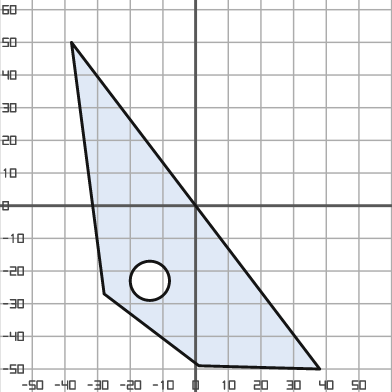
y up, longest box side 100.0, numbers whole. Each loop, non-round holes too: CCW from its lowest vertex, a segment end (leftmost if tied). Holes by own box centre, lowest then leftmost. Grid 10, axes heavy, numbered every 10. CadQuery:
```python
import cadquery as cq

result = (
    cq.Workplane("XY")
    .moveTo(38.0, -50.0)
    .lineTo(-38.0, 50.0)
    .lineTo(-28.0, -27.0)
    .lineTo(1.0, -49.0)
    .close()
    .moveTo(-14.0, -23.0)
    .circle(6.0)
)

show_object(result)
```